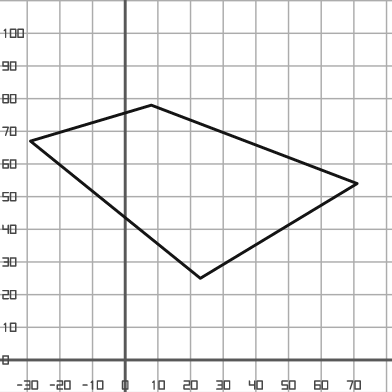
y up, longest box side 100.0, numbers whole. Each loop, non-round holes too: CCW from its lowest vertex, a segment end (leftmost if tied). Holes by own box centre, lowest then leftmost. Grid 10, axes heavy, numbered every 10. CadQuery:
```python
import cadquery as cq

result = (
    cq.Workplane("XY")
    .moveTo(23.0, 25.0)
    .lineTo(71.0, 54.0)
    .lineTo(8.0, 78.0)
    .lineTo(-29.0, 67.0)
    .close()
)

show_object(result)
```